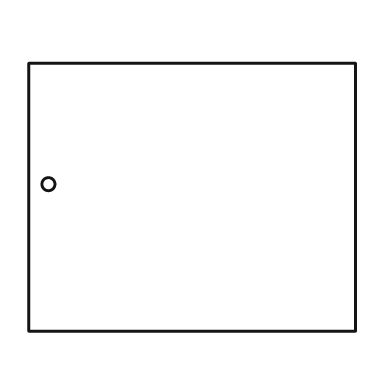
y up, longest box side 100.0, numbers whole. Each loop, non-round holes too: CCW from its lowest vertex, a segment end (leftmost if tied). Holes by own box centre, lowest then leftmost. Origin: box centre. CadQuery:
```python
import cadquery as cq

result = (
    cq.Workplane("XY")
    .moveTo(-50.0, -41.0)
    .lineTo(50.0, -41.0)
    .lineTo(50.0, 41.0)
    .lineTo(-50.0, 41.0)
    .close()
    .moveTo(-44.0, 4.0)
    .circle(2.0)
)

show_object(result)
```